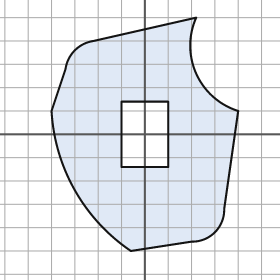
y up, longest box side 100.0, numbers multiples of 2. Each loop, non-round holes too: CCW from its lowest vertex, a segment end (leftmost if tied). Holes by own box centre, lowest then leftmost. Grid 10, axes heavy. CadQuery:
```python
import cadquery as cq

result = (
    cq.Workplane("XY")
    .moveTo(-6.0, -50.0)
    .lineTo(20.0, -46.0)
    .threePointArc((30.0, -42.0), (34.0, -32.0))
    .lineTo(40.0, 10.0)
    .threePointArc((22.0, 26.0), (22.0, 50.0))
    .lineTo(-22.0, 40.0)
    .threePointArc((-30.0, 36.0), (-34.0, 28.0))
    .lineTo(-40.0, 10.0)
    .threePointArc((-30.0, -24.0), (-6.0, -50.0))
    .close()
    .moveTo(-10.0, -14.0)
    .lineTo(10.0, -14.0)
    .lineTo(10.0, 14.0)
    .lineTo(-10.0, 14.0)
    .close()
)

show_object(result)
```